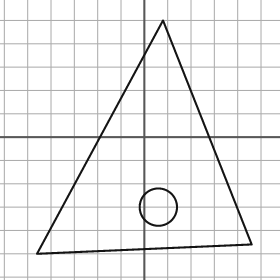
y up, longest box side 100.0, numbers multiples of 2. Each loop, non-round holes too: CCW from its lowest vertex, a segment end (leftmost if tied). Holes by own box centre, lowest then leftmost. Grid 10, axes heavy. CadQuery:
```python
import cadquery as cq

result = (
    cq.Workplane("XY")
    .moveTo(-46.0, -50.0)
    .lineTo(46.0, -46.0)
    .lineTo(8.0, 50.0)
    .close()
    .moveTo(6.0, -30.0)
    .circle(8.0)
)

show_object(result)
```